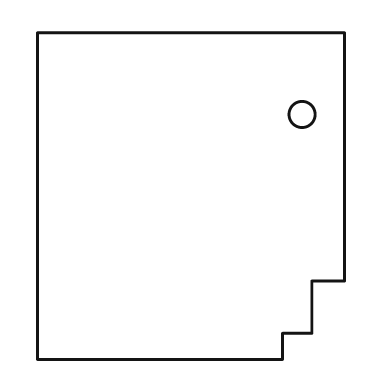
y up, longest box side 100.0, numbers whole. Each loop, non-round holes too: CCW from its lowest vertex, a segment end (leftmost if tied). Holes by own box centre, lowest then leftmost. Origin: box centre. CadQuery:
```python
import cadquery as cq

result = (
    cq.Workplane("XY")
    .moveTo(-47.0, -50.0)
    .lineTo(28.0, -50.0)
    .lineTo(28.0, -42.0)
    .lineTo(37.0, -42.0)
    .lineTo(37.0, -26.0)
    .lineTo(47.0, -26.0)
    .lineTo(47.0, 50.0)
    .lineTo(-47.0, 50.0)
    .close()
    .moveTo(34.0, 25.0)
    .circle(4.0)
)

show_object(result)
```